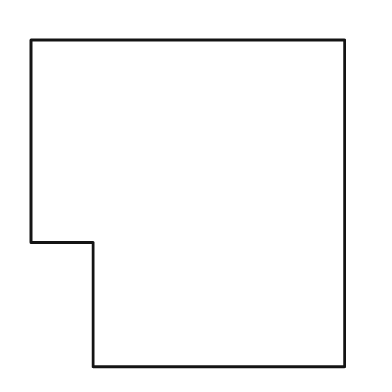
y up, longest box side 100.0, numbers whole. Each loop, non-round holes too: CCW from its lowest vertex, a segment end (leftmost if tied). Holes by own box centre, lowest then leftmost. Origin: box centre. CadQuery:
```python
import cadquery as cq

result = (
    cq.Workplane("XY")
    .moveTo(-29.0, -50.0)
    .lineTo(48.0, -50.0)
    .lineTo(48.0, 50.0)
    .lineTo(-48.0, 50.0)
    .lineTo(-48.0, -12.0)
    .lineTo(-29.0, -12.0)
    .close()
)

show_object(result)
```